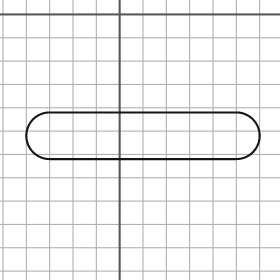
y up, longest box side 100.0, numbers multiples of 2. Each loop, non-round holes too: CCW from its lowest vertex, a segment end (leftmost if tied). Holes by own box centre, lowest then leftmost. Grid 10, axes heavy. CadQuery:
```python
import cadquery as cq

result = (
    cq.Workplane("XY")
    .moveTo(-30.0, -62.0)
    .lineTo(50.0, -62.0)
    .threePointArc((60.0, -52.0), (50.0, -42.0))
    .lineTo(-30.0, -42.0)
    .threePointArc((-40.0, -52.0), (-30.0, -62.0))
    .close()
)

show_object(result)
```